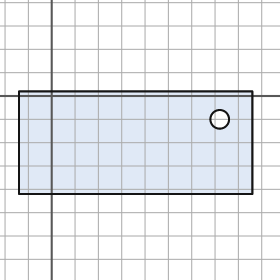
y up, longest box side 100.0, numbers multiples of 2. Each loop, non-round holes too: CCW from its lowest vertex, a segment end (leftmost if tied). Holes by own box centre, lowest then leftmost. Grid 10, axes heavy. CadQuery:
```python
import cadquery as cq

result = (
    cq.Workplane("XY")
    .moveTo(-14.0, -42.0)
    .lineTo(86.0, -42.0)
    .lineTo(86.0, 2.0)
    .lineTo(-14.0, 2.0)
    .close()
    .moveTo(72.0, -10.0)
    .circle(4.0)
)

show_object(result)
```